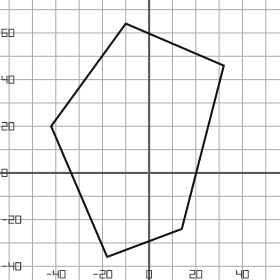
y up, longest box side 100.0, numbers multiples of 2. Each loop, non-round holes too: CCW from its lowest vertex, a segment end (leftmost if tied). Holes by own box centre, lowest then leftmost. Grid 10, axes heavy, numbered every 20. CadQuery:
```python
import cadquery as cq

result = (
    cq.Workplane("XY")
    .moveTo(-18.0, -36.0)
    .lineTo(14.0, -24.0)
    .lineTo(32.0, 46.0)
    .lineTo(-10.0, 64.0)
    .lineTo(-42.0, 20.0)
    .close()
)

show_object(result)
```